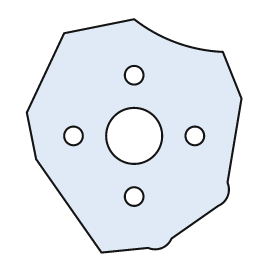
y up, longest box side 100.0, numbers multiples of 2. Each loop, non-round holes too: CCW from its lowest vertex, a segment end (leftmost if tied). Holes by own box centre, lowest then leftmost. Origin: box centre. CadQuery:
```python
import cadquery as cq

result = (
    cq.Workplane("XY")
    .moveTo(-14.0, -50.0)
    .lineTo(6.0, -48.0)
    .threePointArc((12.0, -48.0), (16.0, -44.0))
    .lineTo(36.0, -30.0)
    .threePointArc((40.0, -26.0), (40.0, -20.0))
    .lineTo(46.0, 16.0)
    .lineTo(38.0, 36.0)
    .threePointArc((18.0, 40.0), (0.0, 50.0))
    .lineTo(-30.0, 44.0)
    .lineTo(-46.0, 10.0)
    .lineTo(-42.0, -10.0)
    .close()
    .moveTo(0.0, -26.0)
    .circle(4.0)
    .moveTo(-26.0, 0.0)
    .circle(4.0)
    .moveTo(0.0, 0.0)
    .circle(12.0)
    .moveTo(26.0, 0.0)
    .circle(4.0)
    .moveTo(0.0, 26.0)
    .circle(4.0)
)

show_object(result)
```